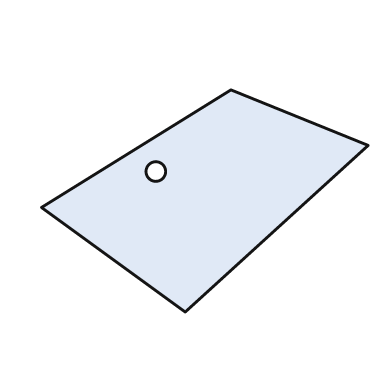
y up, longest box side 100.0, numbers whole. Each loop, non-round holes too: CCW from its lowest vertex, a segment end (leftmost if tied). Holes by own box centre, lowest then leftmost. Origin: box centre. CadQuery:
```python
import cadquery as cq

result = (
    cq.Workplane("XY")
    .moveTo(-6.0, -34.0)
    .lineTo(50.0, 17.0)
    .lineTo(8.0, 34.0)
    .lineTo(-50.0, -2.0)
    .close()
    .moveTo(-15.0, 9.0)
    .circle(3.0)
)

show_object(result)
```